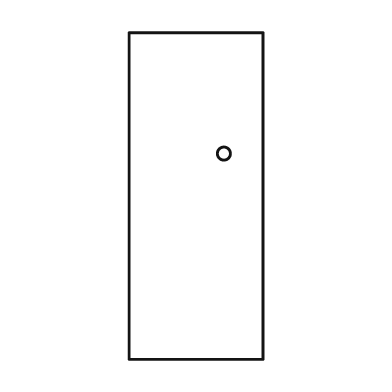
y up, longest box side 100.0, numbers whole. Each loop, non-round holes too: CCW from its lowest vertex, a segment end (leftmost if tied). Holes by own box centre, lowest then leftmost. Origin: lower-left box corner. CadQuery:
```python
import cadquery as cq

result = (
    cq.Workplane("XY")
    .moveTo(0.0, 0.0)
    .lineTo(41.0, 0.0)
    .lineTo(41.0, 100.0)
    .lineTo(0.0, 100.0)
    .close()
    .moveTo(29.0, 63.0)
    .circle(2.0)
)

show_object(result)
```